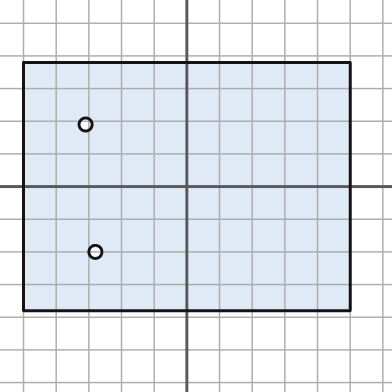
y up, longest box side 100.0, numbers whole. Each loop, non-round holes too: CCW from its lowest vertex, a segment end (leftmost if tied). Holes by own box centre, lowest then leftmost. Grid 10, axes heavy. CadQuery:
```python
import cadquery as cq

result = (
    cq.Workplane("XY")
    .moveTo(-50.0, -38.0)
    .lineTo(50.0, -38.0)
    .lineTo(50.0, 38.0)
    .lineTo(-50.0, 38.0)
    .close()
    .moveTo(-28.0, -20.0)
    .circle(2.0)
    .moveTo(-31.0, 19.0)
    .circle(2.0)
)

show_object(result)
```